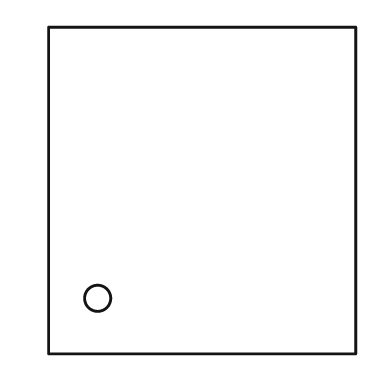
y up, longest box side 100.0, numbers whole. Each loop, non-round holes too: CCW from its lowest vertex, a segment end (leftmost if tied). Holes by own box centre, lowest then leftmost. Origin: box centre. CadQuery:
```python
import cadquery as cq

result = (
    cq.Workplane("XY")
    .moveTo(-47.0, -50.0)
    .lineTo(47.0, -50.0)
    .lineTo(47.0, 50.0)
    .lineTo(-47.0, 50.0)
    .close()
    .moveTo(-32.0, -33.0)
    .circle(4.0)
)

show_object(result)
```